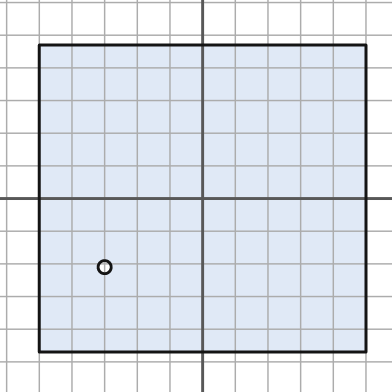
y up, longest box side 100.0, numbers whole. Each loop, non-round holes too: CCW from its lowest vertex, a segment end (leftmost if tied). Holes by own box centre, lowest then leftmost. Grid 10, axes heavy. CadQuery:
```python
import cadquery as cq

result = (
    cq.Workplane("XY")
    .moveTo(-50.0, -47.0)
    .lineTo(50.0, -47.0)
    .lineTo(50.0, 47.0)
    .lineTo(-50.0, 47.0)
    .close()
    .moveTo(-30.0, -21.0)
    .circle(2.0)
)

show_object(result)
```